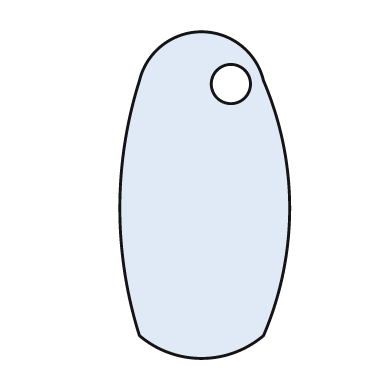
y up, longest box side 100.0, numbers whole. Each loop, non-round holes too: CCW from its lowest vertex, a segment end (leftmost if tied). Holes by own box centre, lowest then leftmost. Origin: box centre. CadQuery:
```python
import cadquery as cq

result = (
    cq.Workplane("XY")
    .moveTo(-20.0, -43.0)
    .threePointArc((-1.0, -50.0), (18.0, -43.0))
    .threePointArc((26.0, -4.0), (18.0, 35.0))
    .threePointArc((-1.0, 50.0), (-20.0, 35.0))
    .threePointArc((-26.0, -4.0), (-20.0, -43.0))
    .close()
    .moveTo(8.0, 34.0)
    .circle(6.0)
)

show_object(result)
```